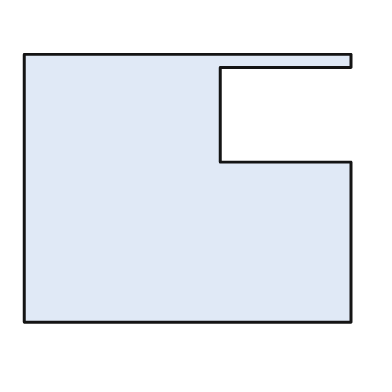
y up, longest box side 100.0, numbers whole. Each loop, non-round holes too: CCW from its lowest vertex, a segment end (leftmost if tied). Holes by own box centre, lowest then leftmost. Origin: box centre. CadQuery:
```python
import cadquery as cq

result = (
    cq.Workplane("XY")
    .moveTo(-50.0, -41.0)
    .lineTo(50.0, -41.0)
    .lineTo(50.0, 8.0)
    .lineTo(10.0, 8.0)
    .lineTo(10.0, 37.0)
    .lineTo(50.0, 37.0)
    .lineTo(50.0, 41.0)
    .lineTo(-50.0, 41.0)
    .close()
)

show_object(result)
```